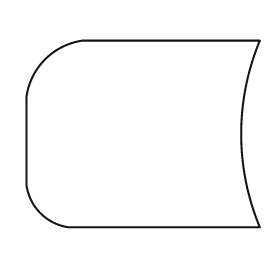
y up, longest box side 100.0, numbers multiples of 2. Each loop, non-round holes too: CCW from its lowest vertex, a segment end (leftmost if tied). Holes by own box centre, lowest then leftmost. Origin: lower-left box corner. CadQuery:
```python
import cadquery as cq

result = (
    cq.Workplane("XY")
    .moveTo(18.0, 0.0)
    .lineTo(100.0, 0.0)
    .threePointArc((92.0, 40.0), (100.0, 80.0))
    .lineTo(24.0, 80.0)
    .threePointArc((8.0, 72.0), (0.0, 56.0))
    .lineTo(0.0, 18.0)
    .threePointArc((6.0, 6.0), (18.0, 0.0))
    .close()
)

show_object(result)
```